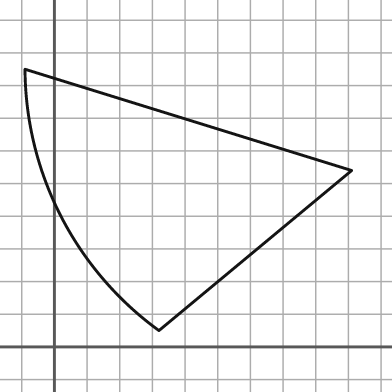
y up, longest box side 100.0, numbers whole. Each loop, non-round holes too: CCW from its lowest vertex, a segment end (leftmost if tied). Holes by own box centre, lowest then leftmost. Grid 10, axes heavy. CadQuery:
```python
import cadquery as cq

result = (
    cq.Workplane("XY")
    .moveTo(32.0, 5.0)
    .lineTo(91.0, 54.0)
    .lineTo(-9.0, 85.0)
    .threePointArc((2.0, 40.0), (32.0, 5.0))
    .close()
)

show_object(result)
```